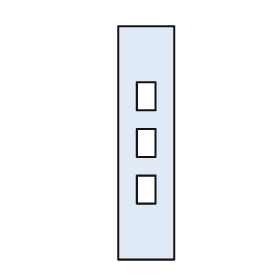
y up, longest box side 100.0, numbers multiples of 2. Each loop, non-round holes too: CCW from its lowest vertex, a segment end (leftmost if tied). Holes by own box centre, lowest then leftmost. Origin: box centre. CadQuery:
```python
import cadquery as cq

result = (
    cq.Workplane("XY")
    .moveTo(-12.0, -50.0)
    .lineTo(12.0, -50.0)
    .lineTo(12.0, 50.0)
    .lineTo(-12.0, 50.0)
    .close()
    .moveTo(-4.0, -26.0)
    .lineTo(4.0, -26.0)
    .lineTo(4.0, -14.0)
    .lineTo(-4.0, -14.0)
    .close()
    .moveTo(-4.0, -6.0)
    .lineTo(4.0, -6.0)
    .lineTo(4.0, 6.0)
    .lineTo(-4.0, 6.0)
    .close()
    .moveTo(-4.0, 14.0)
    .lineTo(4.0, 14.0)
    .lineTo(4.0, 26.0)
    .lineTo(-4.0, 26.0)
    .close()
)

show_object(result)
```